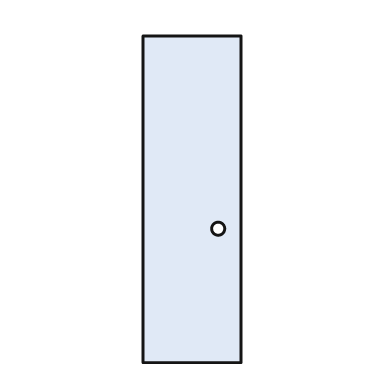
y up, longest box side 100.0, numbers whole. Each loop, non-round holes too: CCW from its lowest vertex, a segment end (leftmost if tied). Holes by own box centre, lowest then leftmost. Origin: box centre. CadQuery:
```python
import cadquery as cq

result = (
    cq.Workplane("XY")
    .moveTo(-15.0, -50.0)
    .lineTo(15.0, -50.0)
    .lineTo(15.0, 50.0)
    .lineTo(-15.0, 50.0)
    .close()
    .moveTo(8.0, -9.0)
    .circle(2.0)
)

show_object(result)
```